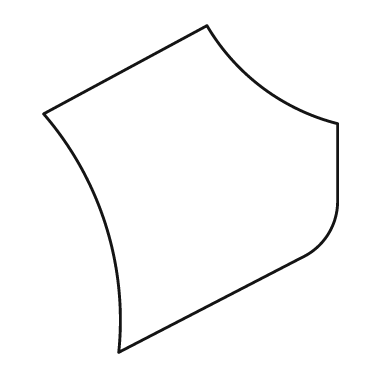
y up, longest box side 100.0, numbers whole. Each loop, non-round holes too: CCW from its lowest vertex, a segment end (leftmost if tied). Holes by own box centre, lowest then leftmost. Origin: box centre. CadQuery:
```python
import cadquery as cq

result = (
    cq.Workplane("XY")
    .moveTo(-22.0, -50.0)
    .lineTo(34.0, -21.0)
    .threePointArc((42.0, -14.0), (45.0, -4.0))
    .lineTo(45.0, 20.0)
    .threePointArc((22.0, 31.0), (5.0, 50.0))
    .lineTo(-45.0, 23.0)
    .threePointArc((-26.0, -11.0), (-22.0, -50.0))
    .close()
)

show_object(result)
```